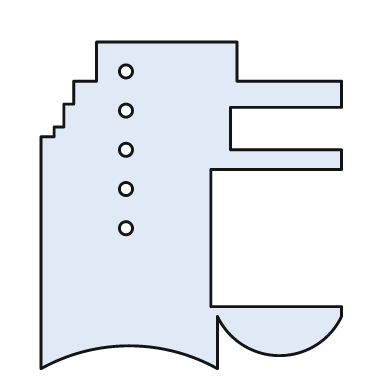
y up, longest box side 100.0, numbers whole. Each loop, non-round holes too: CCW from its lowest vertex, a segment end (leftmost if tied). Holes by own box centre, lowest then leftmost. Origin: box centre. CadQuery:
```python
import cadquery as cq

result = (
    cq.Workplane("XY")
    .moveTo(-46.0, -50.0)
    .threePointArc((-19.0, -43.0), (8.0, -50.0))
    .lineTo(8.0, -34.0)
    .threePointArc((27.0, -46.0), (46.0, -34.0))
    .lineTo(46.0, -31.0)
    .lineTo(6.0, -31.0)
    .lineTo(6.0, 11.0)
    .lineTo(46.0, 11.0)
    .lineTo(46.0, 17.0)
    .lineTo(12.0, 17.0)
    .lineTo(12.0, 30.0)
    .lineTo(46.0, 30.0)
    .lineTo(46.0, 38.0)
    .lineTo(14.0, 38.0)
    .lineTo(14.0, 50.0)
    .lineTo(-29.0, 50.0)
    .lineTo(-29.0, 38.0)
    .lineTo(-36.0, 38.0)
    .lineTo(-36.0, 31.0)
    .lineTo(-39.0, 31.0)
    .lineTo(-39.0, 24.0)
    .lineTo(-42.0, 24.0)
    .lineTo(-42.0, 21.0)
    .lineTo(-46.0, 21.0)
    .close()
    .moveTo(-20.0, -7.0)
    .circle(2.0)
    .moveTo(-20.0, 5.0)
    .circle(2.0)
    .moveTo(-20.0, 17.0)
    .circle(2.0)
    .moveTo(-20.0, 29.0)
    .circle(2.0)
    .moveTo(-20.0, 41.0)
    .circle(2.0)
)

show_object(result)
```